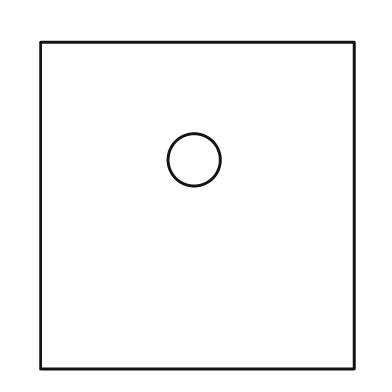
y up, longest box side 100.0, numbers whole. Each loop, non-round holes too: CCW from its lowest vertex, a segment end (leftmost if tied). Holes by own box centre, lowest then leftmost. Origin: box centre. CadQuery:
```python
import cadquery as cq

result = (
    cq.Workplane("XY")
    .moveTo(-48.0, -50.0)
    .lineTo(48.0, -50.0)
    .lineTo(48.0, 50.0)
    .lineTo(-48.0, 50.0)
    .close()
    .moveTo(-1.0, 14.0)
    .circle(8.0)
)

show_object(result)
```